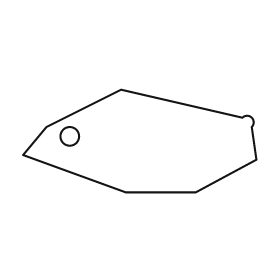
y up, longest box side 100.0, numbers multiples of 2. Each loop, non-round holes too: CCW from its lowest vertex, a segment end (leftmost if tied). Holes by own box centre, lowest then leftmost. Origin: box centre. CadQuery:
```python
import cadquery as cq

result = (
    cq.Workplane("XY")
    .moveTo(-6.0, -22.0)
    .lineTo(24.0, -22.0)
    .lineTo(50.0, -8.0)
    .lineTo(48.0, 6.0)
    .threePointArc((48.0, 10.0), (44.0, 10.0))
    .lineTo(-8.0, 22.0)
    .lineTo(-40.0, 6.0)
    .lineTo(-50.0, -6.0)
    .close()
    .moveTo(-30.0, 2.0)
    .circle(4.0)
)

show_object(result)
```